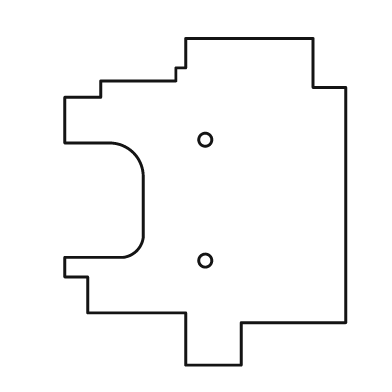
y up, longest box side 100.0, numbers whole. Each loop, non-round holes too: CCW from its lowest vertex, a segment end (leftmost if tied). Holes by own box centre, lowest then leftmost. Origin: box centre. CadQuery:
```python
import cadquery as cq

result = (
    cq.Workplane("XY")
    .moveTo(-6.0, -50.0)
    .lineTo(11.0, -50.0)
    .lineTo(11.0, -37.0)
    .lineTo(43.0, -37.0)
    .lineTo(43.0, 35.0)
    .lineTo(33.0, 35.0)
    .lineTo(33.0, 50.0)
    .lineTo(-6.0, 50.0)
    .lineTo(-6.0, 41.0)
    .lineTo(-9.0, 41.0)
    .lineTo(-9.0, 37.0)
    .lineTo(-32.0, 37.0)
    .lineTo(-32.0, 32.0)
    .lineTo(-43.0, 32.0)
    .lineTo(-43.0, 18.0)
    .lineTo(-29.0, 18.0)
    .threePointArc((-22.0, 15.0), (-19.0, 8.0))
    .lineTo(-19.0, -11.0)
    .threePointArc((-21.0, -15.0), (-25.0, -17.0))
    .lineTo(-43.0, -17.0)
    .lineTo(-43.0, -23.0)
    .lineTo(-36.0, -23.0)
    .lineTo(-36.0, -34.0)
    .lineTo(-6.0, -34.0)
    .close()
    .moveTo(0.0, -18.0)
    .circle(2.0)
    .moveTo(0.0, 19.0)
    .circle(2.0)
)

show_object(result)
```